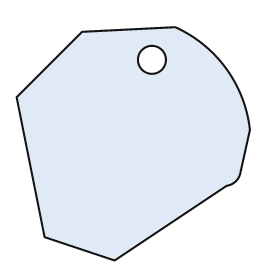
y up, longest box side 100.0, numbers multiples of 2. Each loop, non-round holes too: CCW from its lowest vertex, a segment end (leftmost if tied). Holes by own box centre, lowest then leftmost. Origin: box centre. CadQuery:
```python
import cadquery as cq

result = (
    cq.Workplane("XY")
    .moveTo(-8.0, -50.0)
    .lineTo(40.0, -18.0)
    .threePointArc((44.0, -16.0), (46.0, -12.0))
    .lineTo(50.0, 6.0)
    .threePointArc((40.0, 32.0), (18.0, 50.0))
    .lineTo(-22.0, 48.0)
    .lineTo(-50.0, 20.0)
    .lineTo(-38.0, -40.0)
    .close()
    .moveTo(8.0, 36.0)
    .circle(6.0)
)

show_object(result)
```